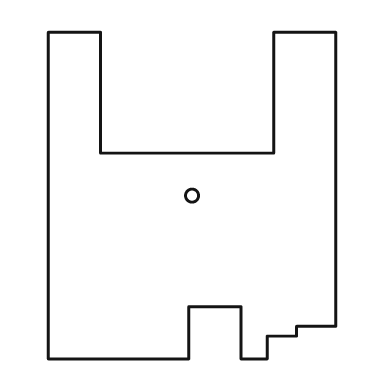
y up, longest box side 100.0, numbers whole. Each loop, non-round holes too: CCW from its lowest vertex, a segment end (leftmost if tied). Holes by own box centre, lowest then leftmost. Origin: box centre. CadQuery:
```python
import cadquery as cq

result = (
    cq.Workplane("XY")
    .moveTo(-44.0, -50.0)
    .lineTo(-1.0, -50.0)
    .lineTo(-1.0, -34.0)
    .lineTo(15.0, -34.0)
    .lineTo(15.0, -50.0)
    .lineTo(23.0, -50.0)
    .lineTo(23.0, -43.0)
    .lineTo(32.0, -43.0)
    .lineTo(32.0, -40.0)
    .lineTo(44.0, -40.0)
    .lineTo(44.0, 50.0)
    .lineTo(25.0, 50.0)
    .lineTo(25.0, 13.0)
    .lineTo(-28.0, 13.0)
    .lineTo(-28.0, 50.0)
    .lineTo(-44.0, 50.0)
    .close()
    .moveTo(0.0, 0.0)
    .circle(2.0)
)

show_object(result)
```